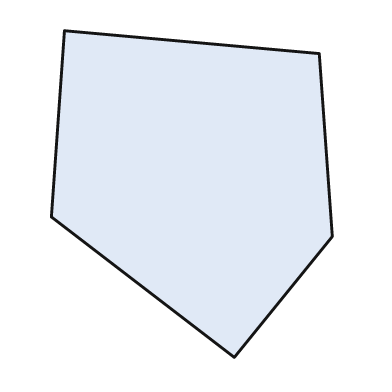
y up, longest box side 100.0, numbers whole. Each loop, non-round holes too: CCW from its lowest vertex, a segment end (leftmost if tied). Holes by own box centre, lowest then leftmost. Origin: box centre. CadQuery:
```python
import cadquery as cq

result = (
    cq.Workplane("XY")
    .moveTo(13.0, -50.0)
    .lineTo(43.0, -13.0)
    .lineTo(39.0, 43.0)
    .lineTo(-39.0, 50.0)
    .lineTo(-43.0, -7.0)
    .close()
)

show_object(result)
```